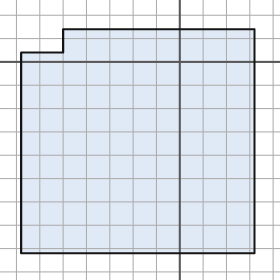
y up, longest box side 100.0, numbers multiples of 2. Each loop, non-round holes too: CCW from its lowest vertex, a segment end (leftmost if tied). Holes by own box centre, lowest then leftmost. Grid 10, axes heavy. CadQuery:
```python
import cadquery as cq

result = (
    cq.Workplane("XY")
    .moveTo(-68.0, -82.0)
    .lineTo(32.0, -82.0)
    .lineTo(32.0, 14.0)
    .lineTo(-50.0, 14.0)
    .lineTo(-50.0, 4.0)
    .lineTo(-68.0, 4.0)
    .close()
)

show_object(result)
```